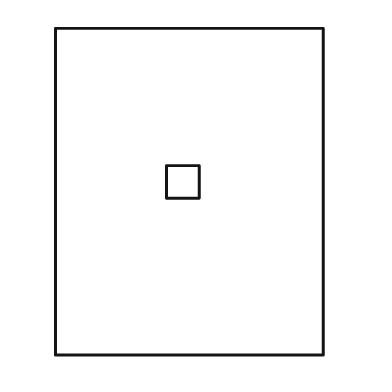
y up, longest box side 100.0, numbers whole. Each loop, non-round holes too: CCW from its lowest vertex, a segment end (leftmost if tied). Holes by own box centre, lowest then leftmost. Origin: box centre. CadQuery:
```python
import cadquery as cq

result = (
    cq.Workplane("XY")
    .moveTo(-41.0, -50.0)
    .lineTo(41.0, -50.0)
    .lineTo(41.0, 50.0)
    .lineTo(-41.0, 50.0)
    .close()
    .moveTo(-7.0, -2.0)
    .lineTo(3.0, -2.0)
    .lineTo(3.0, 8.0)
    .lineTo(-7.0, 8.0)
    .close()
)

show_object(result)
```